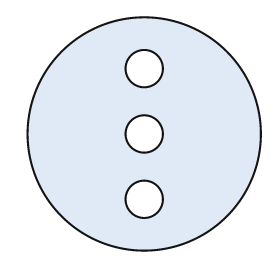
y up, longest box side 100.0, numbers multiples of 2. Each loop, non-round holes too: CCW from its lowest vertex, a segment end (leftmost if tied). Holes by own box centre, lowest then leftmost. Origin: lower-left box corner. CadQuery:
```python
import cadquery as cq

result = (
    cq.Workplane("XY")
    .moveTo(50.0, 50.0)
    .circle(50.0)
    .moveTo(50.0, 22.0)
    .circle(8.0)
    .moveTo(50.0, 50.0)
    .circle(8.0)
    .moveTo(50.0, 78.0)
    .circle(8.0)
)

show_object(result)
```